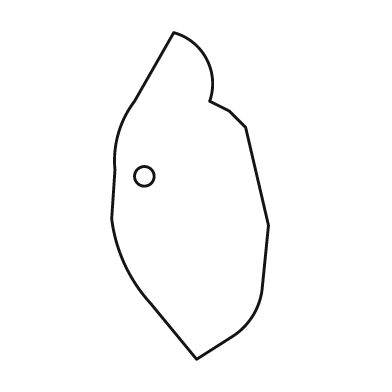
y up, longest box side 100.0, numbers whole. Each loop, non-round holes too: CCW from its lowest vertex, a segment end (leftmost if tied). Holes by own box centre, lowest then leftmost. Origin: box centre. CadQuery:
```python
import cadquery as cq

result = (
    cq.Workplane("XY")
    .moveTo(2.0, -50.0)
    .lineTo(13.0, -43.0)
    .threePointArc((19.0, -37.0), (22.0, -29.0))
    .lineTo(24.0, -9.0)
    .lineTo(17.0, 21.0)
    .lineTo(12.0, 26.0)
    .lineTo(6.0, 29.0)
    .threePointArc((5.0, 42.0), (-5.0, 50.0))
    .lineTo(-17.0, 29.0)
    .threePointArc((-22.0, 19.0), (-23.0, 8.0))
    .lineTo(-24.0, -7.0)
    .threePointArc((-20.0, -21.0), (-12.0, -33.0))
    .close()
    .moveTo(-14.0, 6.0)
    .circle(3.0)
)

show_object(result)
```